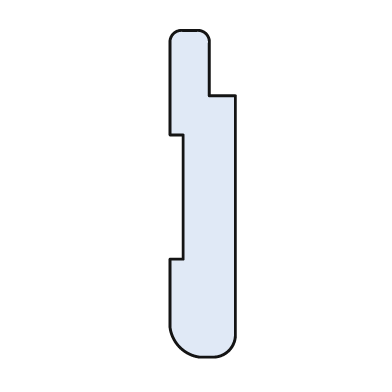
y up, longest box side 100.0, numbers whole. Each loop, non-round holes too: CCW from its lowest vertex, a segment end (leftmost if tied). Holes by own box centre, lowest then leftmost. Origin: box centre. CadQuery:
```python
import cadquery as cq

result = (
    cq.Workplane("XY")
    .moveTo(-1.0, -50.0)
    .lineTo(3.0, -50.0)
    .threePointArc((8.0, -48.0), (10.0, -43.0))
    .lineTo(10.0, 30.0)
    .lineTo(2.0, 30.0)
    .lineTo(2.0, 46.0)
    .threePointArc((1.0, 49.0), (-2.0, 50.0))
    .lineTo(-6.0, 50.0)
    .threePointArc((-9.0, 49.0), (-10.0, 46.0))
    .lineTo(-10.0, 18.0)
    .lineTo(-6.0, 18.0)
    .lineTo(-6.0, -20.0)
    .lineTo(-10.0, -20.0)
    .lineTo(-10.0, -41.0)
    .threePointArc((-7.0, -47.0), (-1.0, -50.0))
    .close()
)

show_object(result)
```